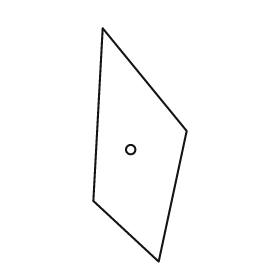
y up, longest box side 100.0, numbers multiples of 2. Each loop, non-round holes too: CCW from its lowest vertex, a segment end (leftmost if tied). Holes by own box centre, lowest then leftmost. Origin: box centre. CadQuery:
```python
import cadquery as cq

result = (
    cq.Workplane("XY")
    .moveTo(8.0, -50.0)
    .lineTo(20.0, 6.0)
    .lineTo(-16.0, 50.0)
    .lineTo(-20.0, -24.0)
    .close()
    .moveTo(-4.0, -2.0)
    .circle(2.0)
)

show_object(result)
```